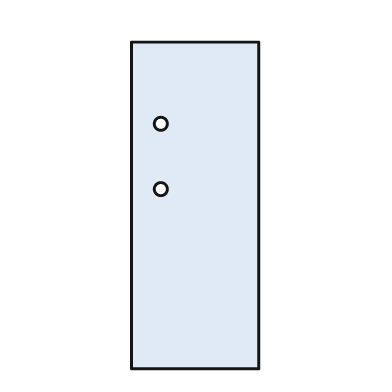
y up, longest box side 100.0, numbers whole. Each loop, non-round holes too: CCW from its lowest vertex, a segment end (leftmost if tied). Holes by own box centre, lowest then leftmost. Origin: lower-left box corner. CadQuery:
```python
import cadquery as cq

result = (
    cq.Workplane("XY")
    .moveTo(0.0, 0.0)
    .lineTo(39.0, 0.0)
    .lineTo(39.0, 100.0)
    .lineTo(0.0, 100.0)
    .close()
    .moveTo(9.0, 55.0)
    .circle(2.0)
    .moveTo(9.0, 75.0)
    .circle(2.0)
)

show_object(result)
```